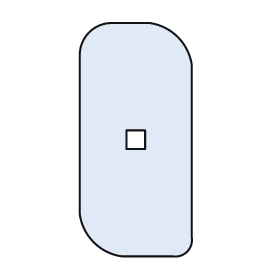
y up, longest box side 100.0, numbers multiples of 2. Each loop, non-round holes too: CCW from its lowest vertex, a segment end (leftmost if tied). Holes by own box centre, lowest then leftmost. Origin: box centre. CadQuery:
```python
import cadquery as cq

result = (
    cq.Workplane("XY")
    .moveTo(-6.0, -50.0)
    .lineTo(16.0, -50.0)
    .threePointArc((22.0, -48.0), (24.0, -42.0))
    .lineTo(24.0, 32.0)
    .threePointArc((18.0, 44.0), (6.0, 50.0))
    .lineTo(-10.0, 50.0)
    .threePointArc((-20.0, 46.0), (-24.0, 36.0))
    .lineTo(-24.0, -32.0)
    .threePointArc((-18.0, -44.0), (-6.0, -50.0))
    .close()
    .moveTo(-4.0, -4.0)
    .lineTo(4.0, -4.0)
    .lineTo(4.0, 4.0)
    .lineTo(-4.0, 4.0)
    .close()
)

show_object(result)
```